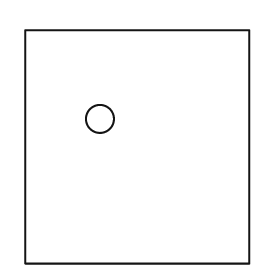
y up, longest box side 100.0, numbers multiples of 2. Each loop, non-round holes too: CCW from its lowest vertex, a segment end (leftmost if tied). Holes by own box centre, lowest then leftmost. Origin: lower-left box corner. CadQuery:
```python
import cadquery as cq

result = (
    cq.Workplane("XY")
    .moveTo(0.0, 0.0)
    .lineTo(96.0, 0.0)
    .lineTo(96.0, 100.0)
    .lineTo(0.0, 100.0)
    .close()
    .moveTo(32.0, 62.0)
    .circle(6.0)
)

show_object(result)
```